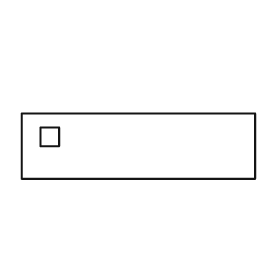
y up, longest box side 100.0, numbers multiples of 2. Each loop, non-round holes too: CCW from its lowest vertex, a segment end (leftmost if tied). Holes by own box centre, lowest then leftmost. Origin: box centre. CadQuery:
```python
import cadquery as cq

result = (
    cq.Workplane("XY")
    .moveTo(-50.0, -14.0)
    .lineTo(50.0, -14.0)
    .lineTo(50.0, 14.0)
    .lineTo(-50.0, 14.0)
    .close()
    .moveTo(-42.0, 0.0)
    .lineTo(-34.0, 0.0)
    .lineTo(-34.0, 8.0)
    .lineTo(-42.0, 8.0)
    .close()
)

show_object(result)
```